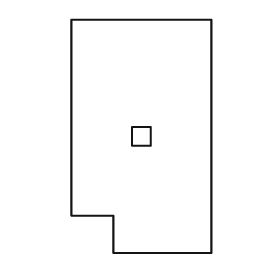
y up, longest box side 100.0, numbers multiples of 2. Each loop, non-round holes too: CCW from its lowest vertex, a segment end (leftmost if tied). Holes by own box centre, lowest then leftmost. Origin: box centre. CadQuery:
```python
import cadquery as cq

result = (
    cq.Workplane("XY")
    .moveTo(-12.0, -50.0)
    .lineTo(30.0, -50.0)
    .lineTo(30.0, 50.0)
    .lineTo(-30.0, 50.0)
    .lineTo(-30.0, -34.0)
    .lineTo(-12.0, -34.0)
    .close()
    .moveTo(-4.0, -4.0)
    .lineTo(4.0, -4.0)
    .lineTo(4.0, 4.0)
    .lineTo(-4.0, 4.0)
    .close()
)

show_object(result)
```